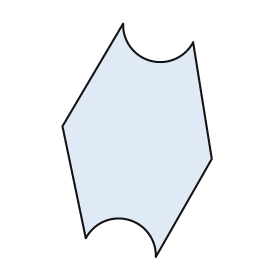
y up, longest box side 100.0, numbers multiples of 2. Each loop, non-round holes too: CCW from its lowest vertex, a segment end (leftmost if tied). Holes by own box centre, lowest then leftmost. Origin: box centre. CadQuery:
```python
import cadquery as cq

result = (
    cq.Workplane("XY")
    .moveTo(8.0, -50.0)
    .lineTo(32.0, -8.0)
    .lineTo(24.0, 42.0)
    .threePointArc((6.0, 34.0), (-6.0, 50.0))
    .lineTo(-32.0, 6.0)
    .lineTo(-22.0, -42.0)
    .threePointArc((-4.0, -34.0), (8.0, -50.0))
    .close()
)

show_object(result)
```